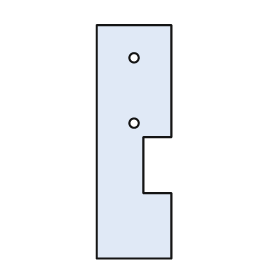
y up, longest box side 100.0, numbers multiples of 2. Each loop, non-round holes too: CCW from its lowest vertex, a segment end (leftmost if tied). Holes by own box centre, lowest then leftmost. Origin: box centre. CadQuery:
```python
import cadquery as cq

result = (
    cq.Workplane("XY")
    .moveTo(-16.0, -50.0)
    .lineTo(16.0, -50.0)
    .lineTo(16.0, -22.0)
    .lineTo(4.0, -22.0)
    .lineTo(4.0, 2.0)
    .lineTo(16.0, 2.0)
    .lineTo(16.0, 50.0)
    .lineTo(-16.0, 50.0)
    .close()
    .moveTo(0.0, 8.0)
    .circle(2.0)
    .moveTo(0.0, 36.0)
    .circle(2.0)
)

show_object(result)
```